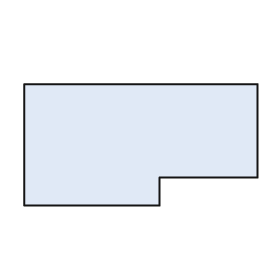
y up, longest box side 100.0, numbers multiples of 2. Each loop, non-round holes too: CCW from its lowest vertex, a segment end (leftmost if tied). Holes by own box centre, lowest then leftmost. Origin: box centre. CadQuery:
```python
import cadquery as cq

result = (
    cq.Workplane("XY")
    .moveTo(-50.0, -26.0)
    .lineTo(8.0, -26.0)
    .lineTo(8.0, -14.0)
    .lineTo(50.0, -14.0)
    .lineTo(50.0, 26.0)
    .lineTo(-50.0, 26.0)
    .close()
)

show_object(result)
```